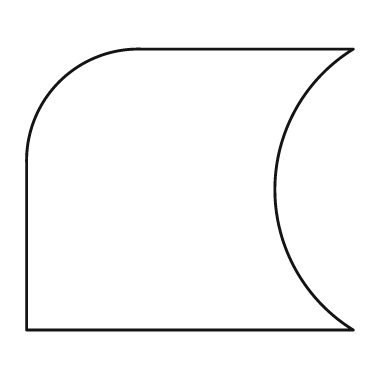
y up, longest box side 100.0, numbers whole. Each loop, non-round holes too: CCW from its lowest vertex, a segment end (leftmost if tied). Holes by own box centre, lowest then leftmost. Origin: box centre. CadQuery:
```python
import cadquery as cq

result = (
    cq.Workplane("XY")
    .moveTo(-50.0, -43.0)
    .lineTo(50.0, -43.0)
    .threePointArc((26.0, 0.0), (50.0, 43.0))
    .lineTo(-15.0, 43.0)
    .threePointArc((-40.0, 33.0), (-50.0, 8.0))
    .close()
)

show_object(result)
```